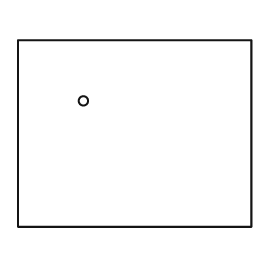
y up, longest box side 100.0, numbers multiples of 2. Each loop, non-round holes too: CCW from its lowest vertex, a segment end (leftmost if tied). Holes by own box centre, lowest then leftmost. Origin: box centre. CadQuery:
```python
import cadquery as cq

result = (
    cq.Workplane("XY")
    .moveTo(-50.0, -40.0)
    .lineTo(50.0, -40.0)
    .lineTo(50.0, 40.0)
    .lineTo(-50.0, 40.0)
    .close()
    .moveTo(-22.0, 14.0)
    .circle(2.0)
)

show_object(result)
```